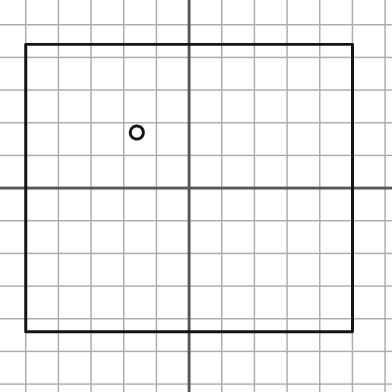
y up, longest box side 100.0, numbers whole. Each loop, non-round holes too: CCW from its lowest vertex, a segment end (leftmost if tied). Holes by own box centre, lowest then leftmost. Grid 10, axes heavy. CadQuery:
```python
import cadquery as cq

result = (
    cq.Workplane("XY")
    .moveTo(-50.0, -44.0)
    .lineTo(50.0, -44.0)
    .lineTo(50.0, 44.0)
    .lineTo(-50.0, 44.0)
    .close()
    .moveTo(-16.0, 17.0)
    .circle(2.0)
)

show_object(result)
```